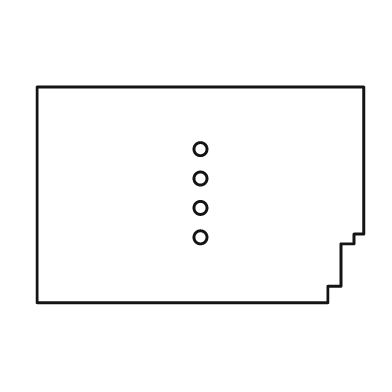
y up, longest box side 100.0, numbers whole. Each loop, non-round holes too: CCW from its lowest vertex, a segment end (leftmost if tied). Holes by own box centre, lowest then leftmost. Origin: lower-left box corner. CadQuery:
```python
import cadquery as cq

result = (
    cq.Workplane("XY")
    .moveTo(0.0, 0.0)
    .lineTo(89.0, 0.0)
    .lineTo(89.0, 5.0)
    .lineTo(93.0, 5.0)
    .lineTo(93.0, 18.0)
    .lineTo(97.0, 18.0)
    .lineTo(97.0, 21.0)
    .lineTo(100.0, 21.0)
    .lineTo(100.0, 66.0)
    .lineTo(0.0, 66.0)
    .close()
    .moveTo(50.0, 20.0)
    .circle(2.0)
    .moveTo(50.0, 29.0)
    .circle(2.0)
    .moveTo(50.0, 38.0)
    .circle(2.0)
    .moveTo(50.0, 47.0)
    .circle(2.0)
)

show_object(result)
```